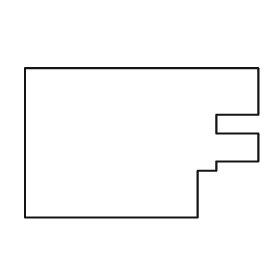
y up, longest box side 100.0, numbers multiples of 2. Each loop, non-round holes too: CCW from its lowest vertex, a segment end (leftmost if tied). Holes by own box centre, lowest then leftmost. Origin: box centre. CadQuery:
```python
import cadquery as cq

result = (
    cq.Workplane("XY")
    .moveTo(-50.0, -32.0)
    .lineTo(24.0, -32.0)
    .lineTo(24.0, -12.0)
    .lineTo(32.0, -12.0)
    .lineTo(32.0, -8.0)
    .lineTo(50.0, -8.0)
    .lineTo(50.0, 4.0)
    .lineTo(32.0, 4.0)
    .lineTo(32.0, 12.0)
    .lineTo(50.0, 12.0)
    .lineTo(50.0, 32.0)
    .lineTo(-50.0, 32.0)
    .close()
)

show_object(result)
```